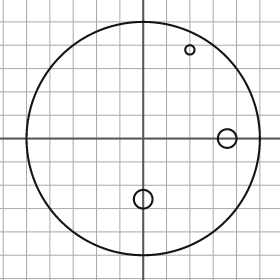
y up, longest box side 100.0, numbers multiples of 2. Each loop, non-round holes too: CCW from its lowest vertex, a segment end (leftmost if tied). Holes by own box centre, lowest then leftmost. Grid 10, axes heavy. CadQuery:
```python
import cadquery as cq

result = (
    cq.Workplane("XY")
    .moveTo(0.0, 0.0)
    .circle(50.0)
    .moveTo(0.0, -26.0)
    .circle(4.0)
    .moveTo(36.0, 0.0)
    .circle(4.0)
    .moveTo(20.0, 38.0)
    .circle(2.0)
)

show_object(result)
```